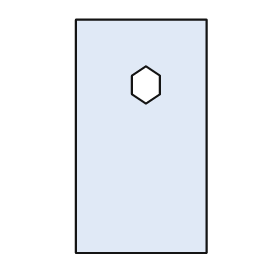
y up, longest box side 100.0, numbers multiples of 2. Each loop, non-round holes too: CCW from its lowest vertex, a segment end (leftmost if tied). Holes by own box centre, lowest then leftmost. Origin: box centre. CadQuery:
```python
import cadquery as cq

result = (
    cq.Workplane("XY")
    .moveTo(-28.0, -50.0)
    .lineTo(28.0, -50.0)
    .lineTo(28.0, 50.0)
    .lineTo(-28.0, 50.0)
    .close()
    .moveTo(2.0, 14.0)
    .lineTo(8.0, 18.0)
    .lineTo(8.0, 26.0)
    .lineTo(2.0, 30.0)
    .lineTo(-4.0, 26.0)
    .lineTo(-4.0, 18.0)
    .close()
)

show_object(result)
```